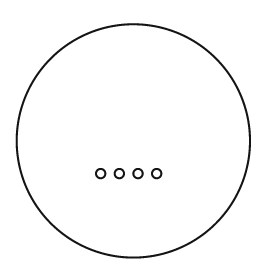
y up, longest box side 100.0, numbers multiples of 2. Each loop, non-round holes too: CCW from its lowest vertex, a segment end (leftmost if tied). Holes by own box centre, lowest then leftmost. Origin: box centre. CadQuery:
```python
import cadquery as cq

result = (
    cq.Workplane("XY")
    .moveTo(0.0, 0.0)
    .circle(50.0)
    .moveTo(-14.0, -14.0)
    .circle(2.0)
    .moveTo(-6.0, -14.0)
    .circle(2.0)
    .moveTo(2.0, -14.0)
    .circle(2.0)
    .moveTo(10.0, -14.0)
    .circle(2.0)
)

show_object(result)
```